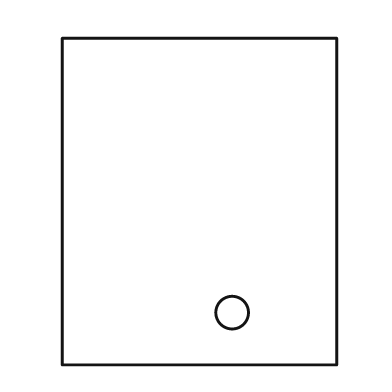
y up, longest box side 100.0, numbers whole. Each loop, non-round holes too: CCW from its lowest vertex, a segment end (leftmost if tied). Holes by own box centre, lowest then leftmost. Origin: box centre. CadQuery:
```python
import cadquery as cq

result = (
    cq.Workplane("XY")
    .moveTo(-42.0, -50.0)
    .lineTo(42.0, -50.0)
    .lineTo(42.0, 50.0)
    .lineTo(-42.0, 50.0)
    .close()
    .moveTo(10.0, -34.0)
    .circle(5.0)
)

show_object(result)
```